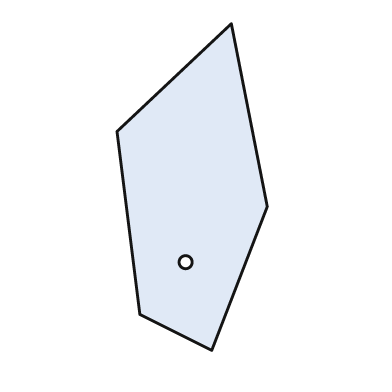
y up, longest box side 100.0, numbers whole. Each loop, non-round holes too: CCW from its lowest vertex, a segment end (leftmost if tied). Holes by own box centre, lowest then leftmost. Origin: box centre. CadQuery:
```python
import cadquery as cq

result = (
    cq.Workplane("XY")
    .moveTo(6.0, -50.0)
    .lineTo(23.0, -6.0)
    .lineTo(12.0, 50.0)
    .lineTo(-23.0, 17.0)
    .lineTo(-16.0, -39.0)
    .close()
    .moveTo(-2.0, -23.0)
    .circle(2.0)
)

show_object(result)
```